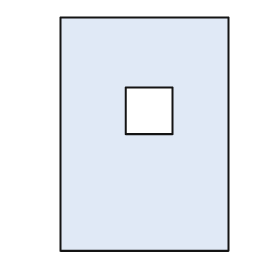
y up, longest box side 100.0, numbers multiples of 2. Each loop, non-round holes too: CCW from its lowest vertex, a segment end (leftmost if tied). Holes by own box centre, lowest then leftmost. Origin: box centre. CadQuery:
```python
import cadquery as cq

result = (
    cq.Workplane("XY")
    .moveTo(-36.0, -50.0)
    .lineTo(36.0, -50.0)
    .lineTo(36.0, 50.0)
    .lineTo(-36.0, 50.0)
    .close()
    .moveTo(-8.0, 0.0)
    .lineTo(12.0, 0.0)
    .lineTo(12.0, 20.0)
    .lineTo(-8.0, 20.0)
    .close()
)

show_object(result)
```